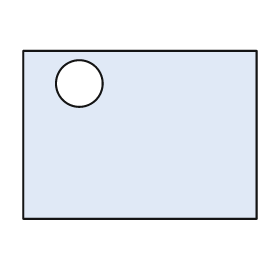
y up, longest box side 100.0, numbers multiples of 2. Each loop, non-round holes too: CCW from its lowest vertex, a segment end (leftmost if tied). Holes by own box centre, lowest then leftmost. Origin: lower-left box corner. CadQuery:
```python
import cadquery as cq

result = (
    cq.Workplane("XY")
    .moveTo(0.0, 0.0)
    .lineTo(100.0, 0.0)
    .lineTo(100.0, 72.0)
    .lineTo(0.0, 72.0)
    .close()
    .moveTo(24.0, 58.0)
    .circle(10.0)
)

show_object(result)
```